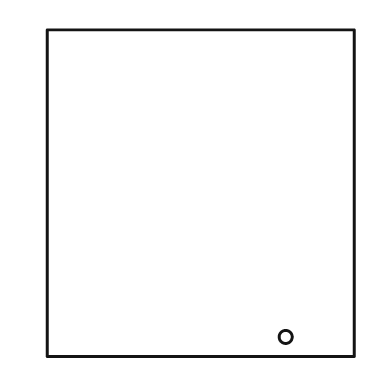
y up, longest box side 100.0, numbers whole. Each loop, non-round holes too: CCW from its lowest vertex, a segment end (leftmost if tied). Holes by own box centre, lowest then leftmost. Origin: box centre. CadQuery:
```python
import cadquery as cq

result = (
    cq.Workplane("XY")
    .moveTo(-47.0, -50.0)
    .lineTo(47.0, -50.0)
    .lineTo(47.0, 50.0)
    .lineTo(-47.0, 50.0)
    .close()
    .moveTo(26.0, -44.0)
    .circle(2.0)
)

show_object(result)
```